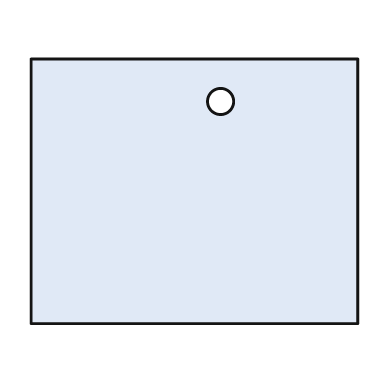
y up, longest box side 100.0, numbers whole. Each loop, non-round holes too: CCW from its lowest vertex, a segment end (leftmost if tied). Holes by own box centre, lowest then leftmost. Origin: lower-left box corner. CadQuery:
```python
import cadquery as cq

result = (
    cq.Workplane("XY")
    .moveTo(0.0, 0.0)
    .lineTo(100.0, 0.0)
    .lineTo(100.0, 81.0)
    .lineTo(0.0, 81.0)
    .close()
    .moveTo(58.0, 68.0)
    .circle(4.0)
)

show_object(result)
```